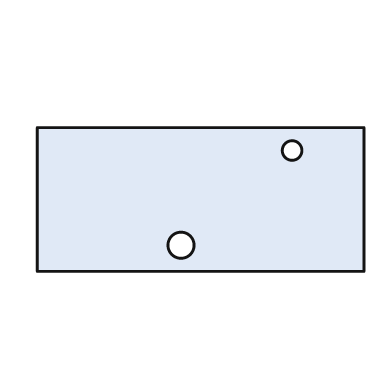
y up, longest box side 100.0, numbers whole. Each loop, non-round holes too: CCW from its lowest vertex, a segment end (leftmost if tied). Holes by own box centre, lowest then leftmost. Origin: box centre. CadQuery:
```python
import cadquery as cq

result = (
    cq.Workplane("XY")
    .moveTo(-50.0, -22.0)
    .lineTo(50.0, -22.0)
    .lineTo(50.0, 22.0)
    .lineTo(-50.0, 22.0)
    .close()
    .moveTo(-6.0, -14.0)
    .circle(4.0)
    .moveTo(28.0, 15.0)
    .circle(3.0)
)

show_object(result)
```